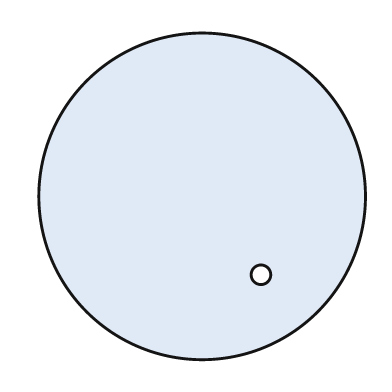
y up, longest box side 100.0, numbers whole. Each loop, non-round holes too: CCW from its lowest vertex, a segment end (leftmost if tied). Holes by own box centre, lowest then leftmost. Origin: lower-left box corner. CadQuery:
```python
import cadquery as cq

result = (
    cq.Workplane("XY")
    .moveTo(50.0, 50.0)
    .circle(50.0)
    .moveTo(68.0, 26.0)
    .circle(3.0)
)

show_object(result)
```